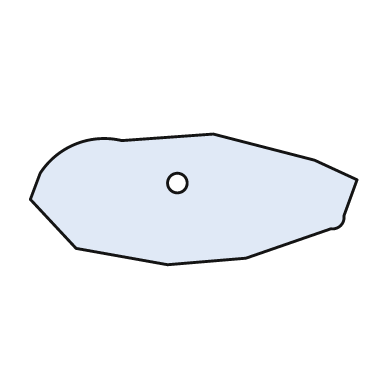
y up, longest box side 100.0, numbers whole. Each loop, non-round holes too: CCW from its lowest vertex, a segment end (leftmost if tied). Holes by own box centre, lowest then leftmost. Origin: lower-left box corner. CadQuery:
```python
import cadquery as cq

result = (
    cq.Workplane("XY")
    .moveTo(42.0, 0.0)
    .lineTo(66.0, 2.0)
    .lineTo(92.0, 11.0)
    .threePointArc((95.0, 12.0), (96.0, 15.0))
    .lineTo(100.0, 26.0)
    .lineTo(87.0, 32.0)
    .lineTo(56.0, 40.0)
    .lineTo(28.0, 38.0)
    .threePointArc((14.0, 37.0), (3.0, 28.0))
    .lineTo(0.0, 20.0)
    .lineTo(14.0, 5.0)
    .close()
    .moveTo(45.0, 25.0)
    .circle(3.0)
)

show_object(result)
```